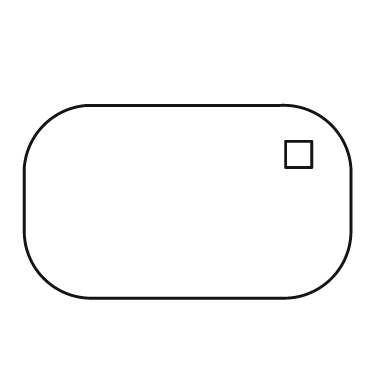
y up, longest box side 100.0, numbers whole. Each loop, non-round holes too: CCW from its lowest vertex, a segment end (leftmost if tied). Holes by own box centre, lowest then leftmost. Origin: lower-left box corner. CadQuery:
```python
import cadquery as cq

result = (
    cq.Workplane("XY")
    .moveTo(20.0, 0.0)
    .lineTo(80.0, 0.0)
    .threePointArc((94.0, 6.0), (100.0, 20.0))
    .lineTo(100.0, 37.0)
    .threePointArc((94.0, 53.0), (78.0, 59.0))
    .lineTo(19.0, 59.0)
    .threePointArc((6.0, 53.0), (0.0, 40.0))
    .lineTo(0.0, 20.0)
    .threePointArc((6.0, 6.0), (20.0, 0.0))
    .close()
    .moveTo(80.0, 40.0)
    .lineTo(88.0, 40.0)
    .lineTo(88.0, 48.0)
    .lineTo(80.0, 48.0)
    .close()
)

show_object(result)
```